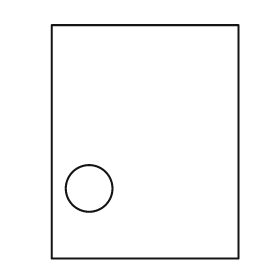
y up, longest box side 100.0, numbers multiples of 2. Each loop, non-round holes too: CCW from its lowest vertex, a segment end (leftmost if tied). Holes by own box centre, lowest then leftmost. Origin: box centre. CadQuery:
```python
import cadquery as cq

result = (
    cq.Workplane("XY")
    .moveTo(-40.0, -50.0)
    .lineTo(40.0, -50.0)
    .lineTo(40.0, 50.0)
    .lineTo(-40.0, 50.0)
    .close()
    .moveTo(-24.0, -20.0)
    .circle(10.0)
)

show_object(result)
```